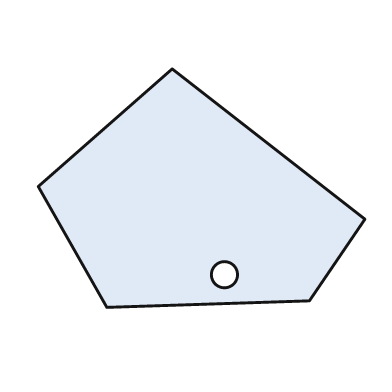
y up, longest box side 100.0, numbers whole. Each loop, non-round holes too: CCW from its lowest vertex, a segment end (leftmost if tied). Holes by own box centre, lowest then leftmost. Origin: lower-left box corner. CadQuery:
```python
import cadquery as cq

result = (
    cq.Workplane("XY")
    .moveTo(21.0, 0.0)
    .lineTo(83.0, 2.0)
    .lineTo(100.0, 27.0)
    .lineTo(41.0, 73.0)
    .lineTo(0.0, 37.0)
    .close()
    .moveTo(57.0, 10.0)
    .circle(4.0)
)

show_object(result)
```